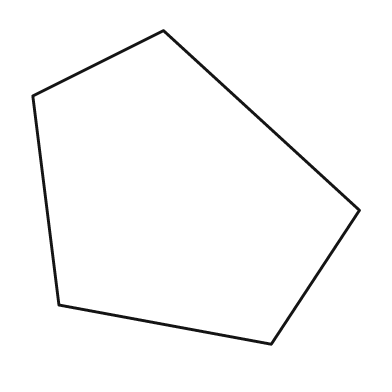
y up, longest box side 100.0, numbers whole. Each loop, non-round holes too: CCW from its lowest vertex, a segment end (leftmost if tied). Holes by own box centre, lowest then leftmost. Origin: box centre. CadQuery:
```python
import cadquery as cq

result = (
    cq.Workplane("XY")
    .moveTo(23.0, -48.0)
    .lineTo(50.0, -7.0)
    .lineTo(-10.0, 48.0)
    .lineTo(-50.0, 28.0)
    .lineTo(-42.0, -36.0)
    .close()
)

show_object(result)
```